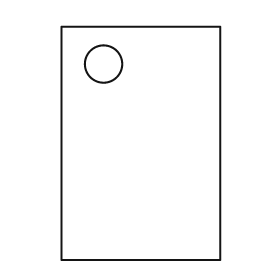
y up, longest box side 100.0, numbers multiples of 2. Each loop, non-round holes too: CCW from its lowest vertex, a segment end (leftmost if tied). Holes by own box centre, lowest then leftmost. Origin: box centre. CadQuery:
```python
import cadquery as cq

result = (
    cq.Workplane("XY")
    .moveTo(-34.0, -50.0)
    .lineTo(34.0, -50.0)
    .lineTo(34.0, 50.0)
    .lineTo(-34.0, 50.0)
    .close()
    .moveTo(-16.0, 34.0)
    .circle(8.0)
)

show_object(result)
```